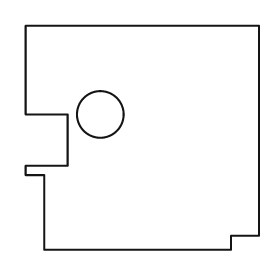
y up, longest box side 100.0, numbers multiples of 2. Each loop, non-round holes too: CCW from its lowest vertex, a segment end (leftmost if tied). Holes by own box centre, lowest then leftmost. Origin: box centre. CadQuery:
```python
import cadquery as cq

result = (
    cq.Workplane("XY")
    .moveTo(-42.0, -48.0)
    .lineTo(38.0, -48.0)
    .lineTo(38.0, -42.0)
    .lineTo(50.0, -42.0)
    .lineTo(50.0, 48.0)
    .lineTo(-50.0, 48.0)
    .lineTo(-50.0, 10.0)
    .lineTo(-32.0, 10.0)
    .lineTo(-32.0, -12.0)
    .lineTo(-50.0, -12.0)
    .lineTo(-50.0, -16.0)
    .lineTo(-42.0, -16.0)
    .close()
    .moveTo(-18.0, 10.0)
    .circle(10.0)
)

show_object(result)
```